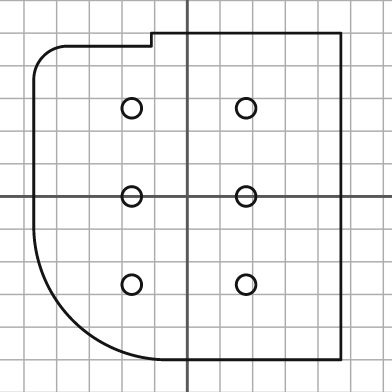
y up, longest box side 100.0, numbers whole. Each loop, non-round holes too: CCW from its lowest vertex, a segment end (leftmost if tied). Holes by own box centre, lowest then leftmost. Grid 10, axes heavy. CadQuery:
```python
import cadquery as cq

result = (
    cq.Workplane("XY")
    .moveTo(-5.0, -50.0)
    .lineTo(47.0, -50.0)
    .lineTo(47.0, 50.0)
    .lineTo(-11.0, 50.0)
    .lineTo(-11.0, 46.0)
    .lineTo(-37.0, 46.0)
    .threePointArc((-44.0, 43.0), (-47.0, 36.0))
    .lineTo(-47.0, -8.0)
    .threePointArc((-35.0, -38.0), (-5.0, -50.0))
    .close()
    .moveTo(-17.0, -27.0)
    .circle(3.0)
    .moveTo(18.0, -27.0)
    .circle(3.0)
    .moveTo(-17.0, 0.0)
    .circle(3.0)
    .moveTo(18.0, 0.0)
    .circle(3.0)
    .moveTo(-17.0, 27.0)
    .circle(3.0)
    .moveTo(18.0, 27.0)
    .circle(3.0)
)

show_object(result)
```